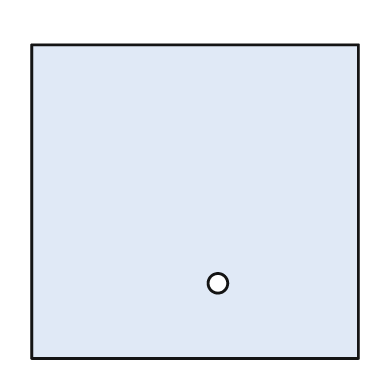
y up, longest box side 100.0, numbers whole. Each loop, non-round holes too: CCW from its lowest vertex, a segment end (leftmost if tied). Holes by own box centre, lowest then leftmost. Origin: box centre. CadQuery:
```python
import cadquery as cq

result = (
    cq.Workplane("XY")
    .moveTo(-50.0, -48.0)
    .lineTo(50.0, -48.0)
    .lineTo(50.0, 48.0)
    .lineTo(-50.0, 48.0)
    .close()
    .moveTo(7.0, -25.0)
    .circle(3.0)
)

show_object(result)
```